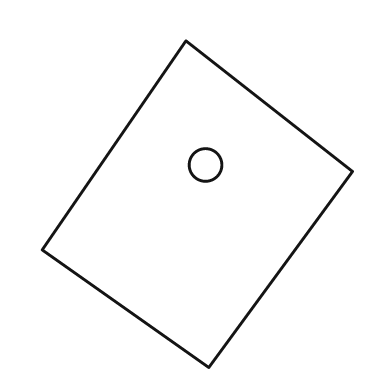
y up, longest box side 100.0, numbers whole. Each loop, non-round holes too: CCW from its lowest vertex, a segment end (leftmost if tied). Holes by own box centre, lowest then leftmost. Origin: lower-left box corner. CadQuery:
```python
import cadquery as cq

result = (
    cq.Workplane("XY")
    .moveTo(51.0, 0.0)
    .lineTo(95.0, 60.0)
    .lineTo(44.0, 100.0)
    .lineTo(0.0, 36.0)
    .close()
    .moveTo(50.0, 62.0)
    .circle(5.0)
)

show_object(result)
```